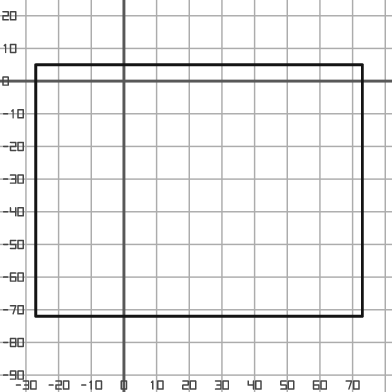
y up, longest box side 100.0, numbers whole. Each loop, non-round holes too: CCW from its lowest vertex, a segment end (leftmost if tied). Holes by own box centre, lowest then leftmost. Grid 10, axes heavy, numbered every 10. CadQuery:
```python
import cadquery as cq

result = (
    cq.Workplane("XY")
    .moveTo(-27.0, -72.0)
    .lineTo(73.0, -72.0)
    .lineTo(73.0, 5.0)
    .lineTo(-27.0, 5.0)
    .close()
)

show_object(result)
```